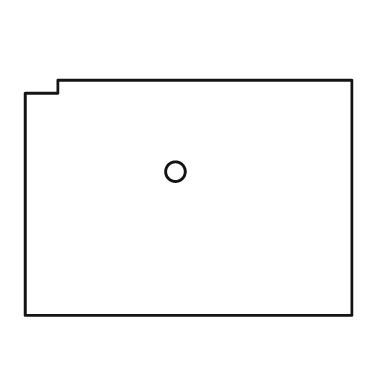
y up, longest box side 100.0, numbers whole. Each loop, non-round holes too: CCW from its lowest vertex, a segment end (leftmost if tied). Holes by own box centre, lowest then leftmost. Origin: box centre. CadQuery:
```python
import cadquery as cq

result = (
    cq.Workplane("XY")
    .moveTo(-50.0, -36.0)
    .lineTo(50.0, -36.0)
    .lineTo(50.0, 36.0)
    .lineTo(-40.0, 36.0)
    .lineTo(-40.0, 32.0)
    .lineTo(-50.0, 32.0)
    .close()
    .moveTo(-4.0, 8.0)
    .circle(3.0)
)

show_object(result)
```